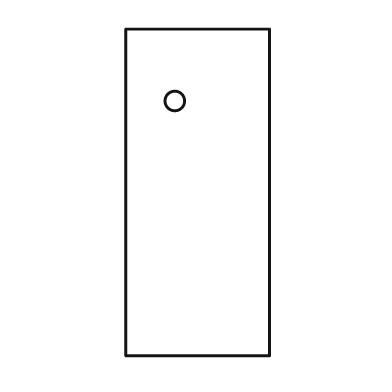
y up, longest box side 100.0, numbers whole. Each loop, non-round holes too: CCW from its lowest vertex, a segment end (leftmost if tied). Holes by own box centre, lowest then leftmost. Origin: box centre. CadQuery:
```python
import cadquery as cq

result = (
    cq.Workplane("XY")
    .moveTo(-22.0, -50.0)
    .lineTo(22.0, -50.0)
    .lineTo(22.0, 50.0)
    .lineTo(-22.0, 50.0)
    .close()
    .moveTo(-7.0, 28.0)
    .circle(3.0)
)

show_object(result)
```